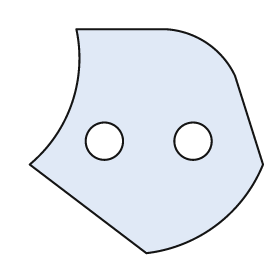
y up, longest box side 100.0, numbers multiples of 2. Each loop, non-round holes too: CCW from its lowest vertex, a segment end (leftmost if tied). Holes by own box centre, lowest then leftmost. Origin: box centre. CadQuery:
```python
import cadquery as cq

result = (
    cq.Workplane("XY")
    .moveTo(0.0, -48.0)
    .threePointArc((30.0, -36.0), (50.0, -10.0))
    .lineTo(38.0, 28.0)
    .threePointArc((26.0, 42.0), (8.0, 48.0))
    .lineTo(-30.0, 48.0)
    .threePointArc((-32.0, 16.0), (-50.0, -10.0))
    .close()
    .moveTo(-18.0, 0.0)
    .circle(8.0)
    .moveTo(20.0, 0.0)
    .circle(8.0)
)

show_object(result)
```